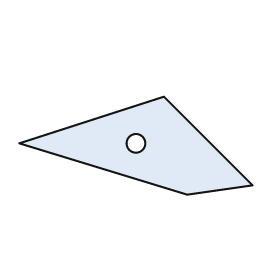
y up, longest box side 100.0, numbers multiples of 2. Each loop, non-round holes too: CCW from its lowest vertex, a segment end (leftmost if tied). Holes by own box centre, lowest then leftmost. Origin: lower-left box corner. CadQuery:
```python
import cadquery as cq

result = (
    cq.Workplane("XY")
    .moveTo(72.0, 0.0)
    .lineTo(100.0, 4.0)
    .lineTo(62.0, 42.0)
    .lineTo(0.0, 22.0)
    .close()
    .moveTo(50.0, 22.0)
    .circle(4.0)
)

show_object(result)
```